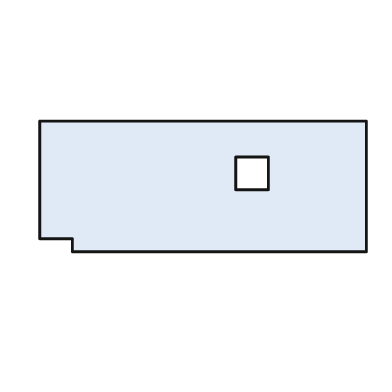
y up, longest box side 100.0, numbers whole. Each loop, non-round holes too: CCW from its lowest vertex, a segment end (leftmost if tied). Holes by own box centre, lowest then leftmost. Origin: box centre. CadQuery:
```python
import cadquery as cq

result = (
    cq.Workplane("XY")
    .moveTo(-40.0, -20.0)
    .lineTo(50.0, -20.0)
    .lineTo(50.0, 20.0)
    .lineTo(-50.0, 20.0)
    .lineTo(-50.0, -16.0)
    .lineTo(-40.0, -16.0)
    .close()
    .moveTo(10.0, -1.0)
    .lineTo(20.0, -1.0)
    .lineTo(20.0, 9.0)
    .lineTo(10.0, 9.0)
    .close()
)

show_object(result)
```